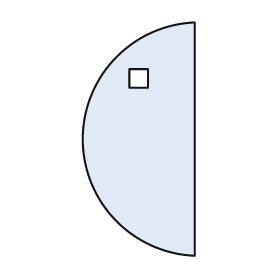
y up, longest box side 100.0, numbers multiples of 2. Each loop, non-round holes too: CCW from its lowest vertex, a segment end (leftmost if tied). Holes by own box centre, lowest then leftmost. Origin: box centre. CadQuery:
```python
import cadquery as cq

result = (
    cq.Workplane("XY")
    .moveTo(24.0, -50.0)
    .lineTo(24.0, 50.0)
    .threePointArc((-24.0, 0.0), (24.0, -50.0))
    .close()
    .moveTo(-4.0, 22.0)
    .lineTo(4.0, 22.0)
    .lineTo(4.0, 30.0)
    .lineTo(-4.0, 30.0)
    .close()
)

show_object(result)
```